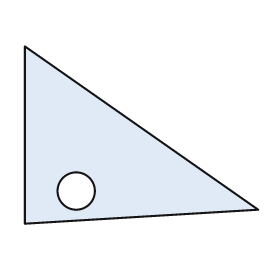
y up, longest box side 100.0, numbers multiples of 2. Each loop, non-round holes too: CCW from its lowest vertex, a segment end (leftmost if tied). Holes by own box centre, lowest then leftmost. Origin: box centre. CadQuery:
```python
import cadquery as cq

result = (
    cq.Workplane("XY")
    .moveTo(-50.0, -38.0)
    .lineTo(50.0, -32.0)
    .lineTo(-50.0, 38.0)
    .close()
    .moveTo(-28.0, -24.0)
    .circle(8.0)
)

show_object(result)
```